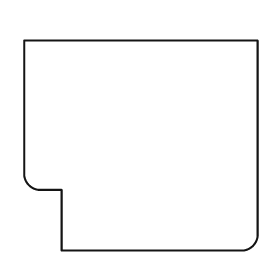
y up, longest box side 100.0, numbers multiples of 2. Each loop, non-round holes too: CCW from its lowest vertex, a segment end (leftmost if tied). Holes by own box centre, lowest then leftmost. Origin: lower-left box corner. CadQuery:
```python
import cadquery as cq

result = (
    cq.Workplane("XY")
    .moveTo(16.0, 0.0)
    .lineTo(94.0, 0.0)
    .threePointArc((98.0, 2.0), (100.0, 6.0))
    .lineTo(100.0, 90.0)
    .lineTo(0.0, 90.0)
    .lineTo(0.0, 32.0)
    .threePointArc((2.0, 28.0), (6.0, 26.0))
    .lineTo(16.0, 26.0)
    .close()
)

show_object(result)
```